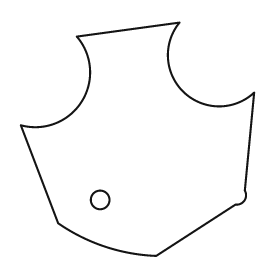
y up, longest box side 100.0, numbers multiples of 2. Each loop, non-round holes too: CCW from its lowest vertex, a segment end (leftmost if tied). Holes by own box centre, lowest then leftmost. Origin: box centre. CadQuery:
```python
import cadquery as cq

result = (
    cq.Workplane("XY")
    .moveTo(8.0, -50.0)
    .lineTo(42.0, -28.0)
    .threePointArc((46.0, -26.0), (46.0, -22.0))
    .lineTo(50.0, 20.0)
    .threePointArc((20.0, 20.0), (18.0, 50.0))
    .lineTo(-26.0, 44.0)
    .threePointArc((-24.0, 16.0), (-50.0, 6.0))
    .lineTo(-34.0, -36.0)
    .threePointArc((-14.0, -46.0), (8.0, -50.0))
    .close()
    .moveTo(-16.0, -26.0)
    .circle(4.0)
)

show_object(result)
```